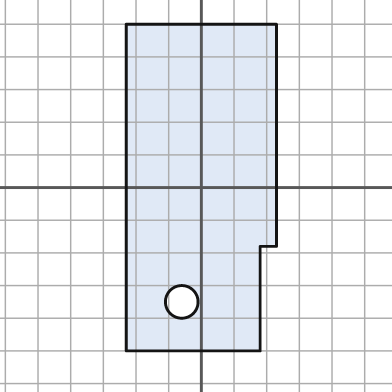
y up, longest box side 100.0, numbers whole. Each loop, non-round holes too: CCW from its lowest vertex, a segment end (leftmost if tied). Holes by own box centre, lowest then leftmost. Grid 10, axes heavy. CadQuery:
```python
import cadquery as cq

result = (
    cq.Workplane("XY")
    .moveTo(-23.0, -50.0)
    .lineTo(18.0, -50.0)
    .lineTo(18.0, -18.0)
    .lineTo(23.0, -18.0)
    .lineTo(23.0, 50.0)
    .lineTo(-23.0, 50.0)
    .close()
    .moveTo(-6.0, -35.0)
    .circle(5.0)
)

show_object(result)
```